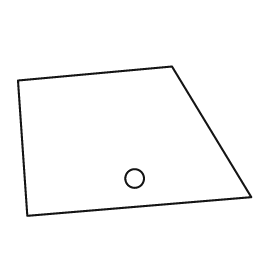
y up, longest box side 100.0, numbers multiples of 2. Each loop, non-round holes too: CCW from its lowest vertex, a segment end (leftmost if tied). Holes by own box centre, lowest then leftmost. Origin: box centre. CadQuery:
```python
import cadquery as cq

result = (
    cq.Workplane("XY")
    .moveTo(-46.0, -32.0)
    .lineTo(50.0, -24.0)
    .lineTo(16.0, 32.0)
    .lineTo(-50.0, 26.0)
    .close()
    .moveTo(0.0, -16.0)
    .circle(4.0)
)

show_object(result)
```